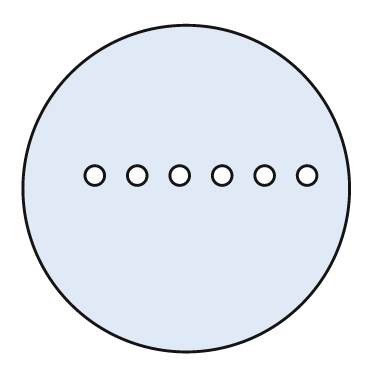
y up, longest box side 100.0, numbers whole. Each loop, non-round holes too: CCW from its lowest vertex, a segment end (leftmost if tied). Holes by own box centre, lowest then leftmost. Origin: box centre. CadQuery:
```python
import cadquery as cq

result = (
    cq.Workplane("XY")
    .moveTo(0.0, 0.0)
    .circle(50.0)
    .moveTo(-28.0, 4.0)
    .circle(3.0)
    .moveTo(-15.0, 4.0)
    .circle(3.0)
    .moveTo(-2.0, 4.0)
    .circle(3.0)
    .moveTo(11.0, 4.0)
    .circle(3.0)
    .moveTo(24.0, 4.0)
    .circle(3.0)
    .moveTo(37.0, 4.0)
    .circle(3.0)
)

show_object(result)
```